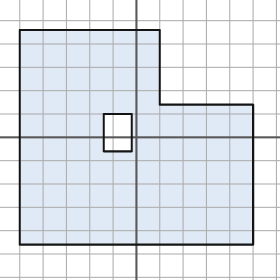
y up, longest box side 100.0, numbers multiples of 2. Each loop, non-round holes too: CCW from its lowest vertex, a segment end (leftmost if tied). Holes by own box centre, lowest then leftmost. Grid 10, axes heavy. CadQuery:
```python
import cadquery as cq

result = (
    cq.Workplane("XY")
    .moveTo(-50.0, -46.0)
    .lineTo(50.0, -46.0)
    .lineTo(50.0, 14.0)
    .lineTo(10.0, 14.0)
    .lineTo(10.0, 46.0)
    .lineTo(-50.0, 46.0)
    .close()
    .moveTo(-14.0, -6.0)
    .lineTo(-2.0, -6.0)
    .lineTo(-2.0, 10.0)
    .lineTo(-14.0, 10.0)
    .close()
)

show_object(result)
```